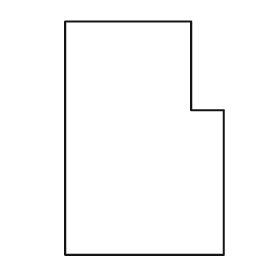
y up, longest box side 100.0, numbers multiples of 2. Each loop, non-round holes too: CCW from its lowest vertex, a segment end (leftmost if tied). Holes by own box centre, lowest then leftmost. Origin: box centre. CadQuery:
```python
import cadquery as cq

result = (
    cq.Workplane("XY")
    .moveTo(-34.0, -50.0)
    .lineTo(34.0, -50.0)
    .lineTo(34.0, 12.0)
    .lineTo(20.0, 12.0)
    .lineTo(20.0, 50.0)
    .lineTo(-34.0, 50.0)
    .close()
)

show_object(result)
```